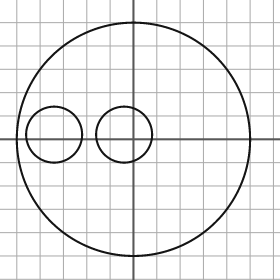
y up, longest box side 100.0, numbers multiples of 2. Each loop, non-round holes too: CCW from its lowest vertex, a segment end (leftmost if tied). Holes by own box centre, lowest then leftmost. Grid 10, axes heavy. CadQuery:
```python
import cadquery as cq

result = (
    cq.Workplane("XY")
    .moveTo(0.0, 0.0)
    .circle(50.0)
    .moveTo(-34.0, 2.0)
    .circle(12.0)
    .moveTo(-4.0, 2.0)
    .circle(12.0)
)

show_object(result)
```